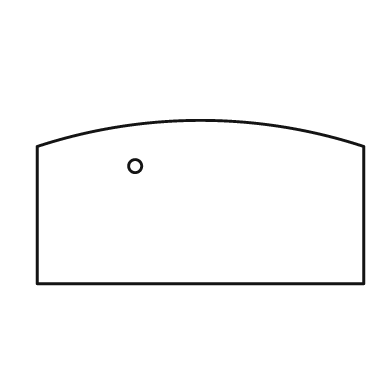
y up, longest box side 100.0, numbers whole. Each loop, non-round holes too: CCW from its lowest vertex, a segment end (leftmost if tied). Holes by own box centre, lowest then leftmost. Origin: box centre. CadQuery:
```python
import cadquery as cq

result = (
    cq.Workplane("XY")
    .moveTo(-50.0, -25.0)
    .lineTo(50.0, -25.0)
    .lineTo(50.0, 17.0)
    .threePointArc((0.0, 25.0), (-50.0, 17.0))
    .close()
    .moveTo(-20.0, 11.0)
    .circle(2.0)
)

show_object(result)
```